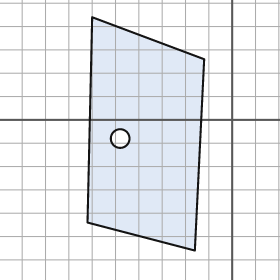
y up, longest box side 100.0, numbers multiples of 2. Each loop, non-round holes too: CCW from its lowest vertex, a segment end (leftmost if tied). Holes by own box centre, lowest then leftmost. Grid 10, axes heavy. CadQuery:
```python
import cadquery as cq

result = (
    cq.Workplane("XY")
    .moveTo(-16.0, -56.0)
    .lineTo(-12.0, 26.0)
    .lineTo(-60.0, 44.0)
    .lineTo(-62.0, -44.0)
    .close()
    .moveTo(-48.0, -8.0)
    .circle(4.0)
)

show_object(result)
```